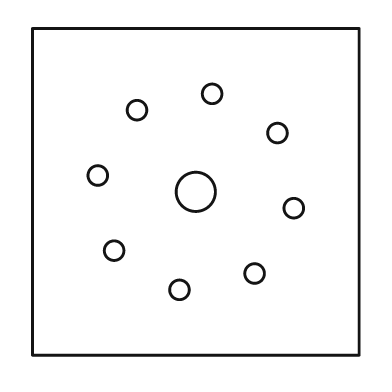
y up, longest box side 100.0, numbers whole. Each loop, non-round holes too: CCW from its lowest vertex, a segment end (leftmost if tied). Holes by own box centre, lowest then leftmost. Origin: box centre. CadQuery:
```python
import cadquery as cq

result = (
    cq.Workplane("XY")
    .moveTo(-50.0, -50.0)
    .lineTo(50.0, -50.0)
    .lineTo(50.0, 50.0)
    .lineTo(-50.0, 50.0)
    .close()
    .moveTo(-5.0, -30.0)
    .circle(3.0)
    .moveTo(18.0, -25.0)
    .circle(3.0)
    .moveTo(-25.0, -18.0)
    .circle(3.0)
    .moveTo(30.0, -5.0)
    .circle(3.0)
    .moveTo(0.0, 0.0)
    .circle(6.0)
    .moveTo(-30.0, 5.0)
    .circle(3.0)
    .moveTo(25.0, 18.0)
    .circle(3.0)
    .moveTo(-18.0, 25.0)
    .circle(3.0)
    .moveTo(5.0, 30.0)
    .circle(3.0)
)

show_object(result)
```